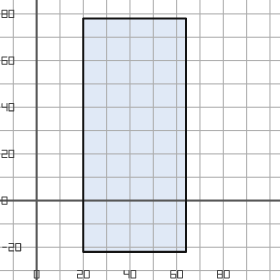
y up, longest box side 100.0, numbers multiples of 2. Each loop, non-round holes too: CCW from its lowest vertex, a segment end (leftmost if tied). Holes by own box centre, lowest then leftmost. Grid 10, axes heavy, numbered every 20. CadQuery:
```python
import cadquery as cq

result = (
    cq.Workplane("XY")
    .moveTo(20.0, -22.0)
    .lineTo(64.0, -22.0)
    .lineTo(64.0, 78.0)
    .lineTo(20.0, 78.0)
    .close()
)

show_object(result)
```